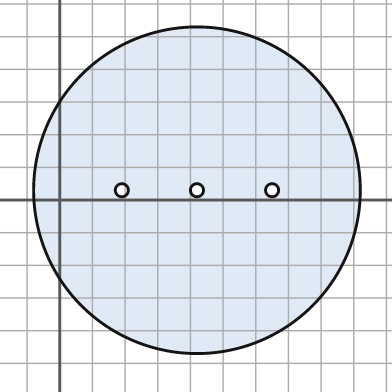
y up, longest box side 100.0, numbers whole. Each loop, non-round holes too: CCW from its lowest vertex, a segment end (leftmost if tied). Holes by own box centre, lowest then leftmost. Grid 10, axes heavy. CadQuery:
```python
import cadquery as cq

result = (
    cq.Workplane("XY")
    .moveTo(42.0, 3.0)
    .circle(50.0)
    .moveTo(19.0, 3.0)
    .circle(2.0)
    .moveTo(42.0, 3.0)
    .circle(2.0)
    .moveTo(65.0, 3.0)
    .circle(2.0)
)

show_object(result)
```